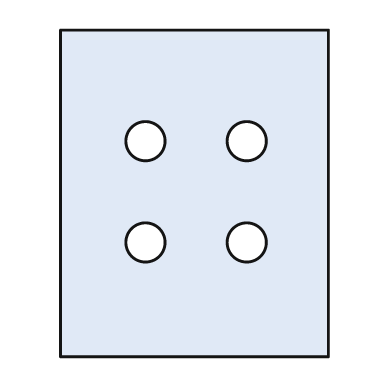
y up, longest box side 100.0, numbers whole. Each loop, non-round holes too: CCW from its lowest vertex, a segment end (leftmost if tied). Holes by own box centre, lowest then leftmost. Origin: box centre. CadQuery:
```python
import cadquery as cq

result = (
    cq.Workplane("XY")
    .moveTo(-41.0, -50.0)
    .lineTo(41.0, -50.0)
    .lineTo(41.0, 50.0)
    .lineTo(-41.0, 50.0)
    .close()
    .moveTo(-15.0, -15.0)
    .circle(6.0)
    .moveTo(16.0, -15.0)
    .circle(6.0)
    .moveTo(-15.0, 16.0)
    .circle(6.0)
    .moveTo(16.0, 16.0)
    .circle(6.0)
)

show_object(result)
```